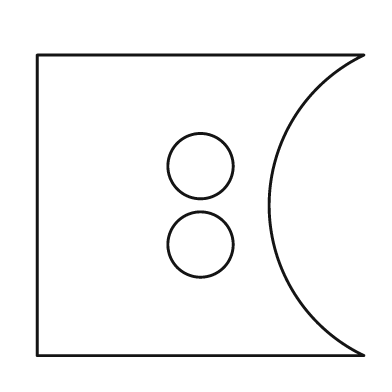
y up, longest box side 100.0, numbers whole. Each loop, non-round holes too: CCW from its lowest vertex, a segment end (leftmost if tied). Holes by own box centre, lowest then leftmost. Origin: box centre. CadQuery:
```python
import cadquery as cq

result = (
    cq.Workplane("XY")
    .moveTo(-50.0, -46.0)
    .lineTo(50.0, -46.0)
    .threePointArc((21.0, 0.0), (50.0, 46.0))
    .lineTo(-50.0, 46.0)
    .close()
    .moveTo(0.0, -12.0)
    .circle(10.0)
    .moveTo(0.0, 12.0)
    .circle(10.0)
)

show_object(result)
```